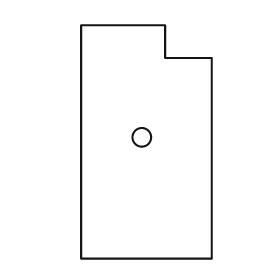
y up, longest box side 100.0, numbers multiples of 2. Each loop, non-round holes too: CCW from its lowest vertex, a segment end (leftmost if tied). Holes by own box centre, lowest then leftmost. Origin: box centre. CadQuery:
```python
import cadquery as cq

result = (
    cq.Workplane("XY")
    .moveTo(-28.0, -50.0)
    .lineTo(28.0, -50.0)
    .lineTo(28.0, 36.0)
    .lineTo(8.0, 36.0)
    .lineTo(8.0, 50.0)
    .lineTo(-28.0, 50.0)
    .close()
    .moveTo(-2.0, 2.0)
    .circle(4.0)
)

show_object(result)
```